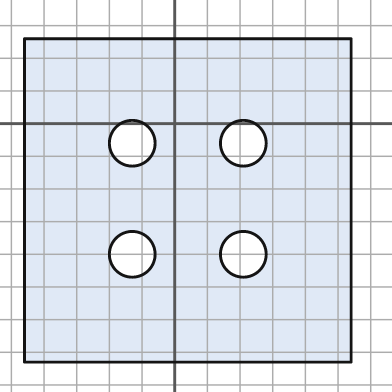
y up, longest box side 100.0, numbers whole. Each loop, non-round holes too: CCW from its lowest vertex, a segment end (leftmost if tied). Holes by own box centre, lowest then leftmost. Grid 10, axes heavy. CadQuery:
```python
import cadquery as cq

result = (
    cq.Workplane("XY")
    .moveTo(-46.0, -73.0)
    .lineTo(54.0, -73.0)
    .lineTo(54.0, 26.0)
    .lineTo(-46.0, 26.0)
    .close()
    .moveTo(-13.0, -40.0)
    .circle(7.0)
    .moveTo(21.0, -40.0)
    .circle(7.0)
    .moveTo(-13.0, -6.0)
    .circle(7.0)
    .moveTo(21.0, -6.0)
    .circle(7.0)
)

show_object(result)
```